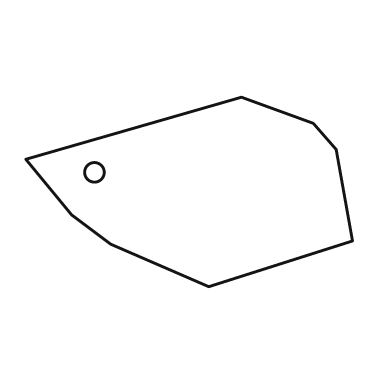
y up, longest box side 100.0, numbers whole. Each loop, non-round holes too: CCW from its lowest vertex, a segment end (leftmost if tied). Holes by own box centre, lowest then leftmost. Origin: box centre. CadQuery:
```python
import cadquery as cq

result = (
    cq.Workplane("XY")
    .moveTo(6.0, -29.0)
    .lineTo(50.0, -15.0)
    .lineTo(45.0, 13.0)
    .lineTo(38.0, 21.0)
    .lineTo(16.0, 29.0)
    .lineTo(-50.0, 10.0)
    .lineTo(-36.0, -7.0)
    .lineTo(-24.0, -16.0)
    .close()
    .moveTo(-29.0, 6.0)
    .circle(3.0)
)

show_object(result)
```